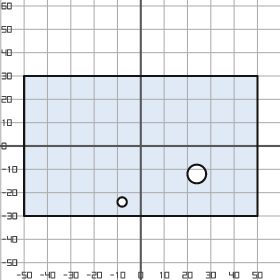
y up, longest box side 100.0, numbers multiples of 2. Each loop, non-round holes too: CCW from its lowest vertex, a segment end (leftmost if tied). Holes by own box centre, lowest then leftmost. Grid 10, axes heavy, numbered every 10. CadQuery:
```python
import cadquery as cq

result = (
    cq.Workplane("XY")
    .moveTo(-50.0, -30.0)
    .lineTo(50.0, -30.0)
    .lineTo(50.0, 30.0)
    .lineTo(-50.0, 30.0)
    .close()
    .moveTo(-8.0, -24.0)
    .circle(2.0)
    .moveTo(24.0, -12.0)
    .circle(4.0)
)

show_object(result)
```